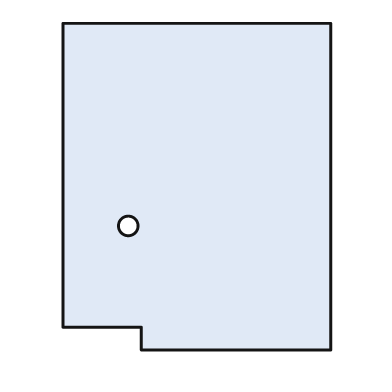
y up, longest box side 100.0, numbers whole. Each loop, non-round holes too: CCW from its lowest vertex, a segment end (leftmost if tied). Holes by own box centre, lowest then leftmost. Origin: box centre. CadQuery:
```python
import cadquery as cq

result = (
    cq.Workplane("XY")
    .moveTo(-17.0, -50.0)
    .lineTo(41.0, -50.0)
    .lineTo(41.0, 50.0)
    .lineTo(-41.0, 50.0)
    .lineTo(-41.0, -43.0)
    .lineTo(-17.0, -43.0)
    .close()
    .moveTo(-21.0, -12.0)
    .circle(3.0)
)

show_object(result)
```